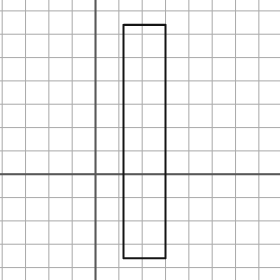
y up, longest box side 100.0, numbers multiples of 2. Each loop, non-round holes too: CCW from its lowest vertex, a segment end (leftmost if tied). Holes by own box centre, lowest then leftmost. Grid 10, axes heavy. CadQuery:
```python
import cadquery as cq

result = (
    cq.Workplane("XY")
    .moveTo(12.0, -36.0)
    .lineTo(30.0, -36.0)
    .lineTo(30.0, 64.0)
    .lineTo(12.0, 64.0)
    .close()
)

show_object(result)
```